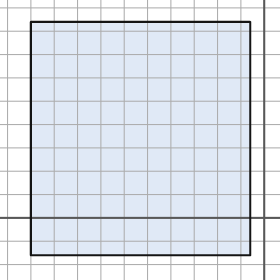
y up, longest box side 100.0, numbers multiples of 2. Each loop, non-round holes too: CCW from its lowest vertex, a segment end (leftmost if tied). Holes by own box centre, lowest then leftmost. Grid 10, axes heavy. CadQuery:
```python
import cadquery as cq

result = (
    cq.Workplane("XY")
    .moveTo(-100.0, -16.0)
    .lineTo(-6.0, -16.0)
    .lineTo(-6.0, 84.0)
    .lineTo(-100.0, 84.0)
    .close()
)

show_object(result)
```